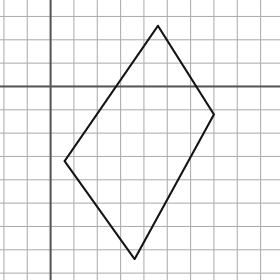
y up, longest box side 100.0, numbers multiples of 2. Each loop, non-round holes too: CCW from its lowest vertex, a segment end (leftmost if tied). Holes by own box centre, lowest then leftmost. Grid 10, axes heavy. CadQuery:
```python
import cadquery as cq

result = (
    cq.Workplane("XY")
    .moveTo(36.0, -74.0)
    .lineTo(70.0, -12.0)
    .lineTo(46.0, 26.0)
    .lineTo(6.0, -32.0)
    .close()
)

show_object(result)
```